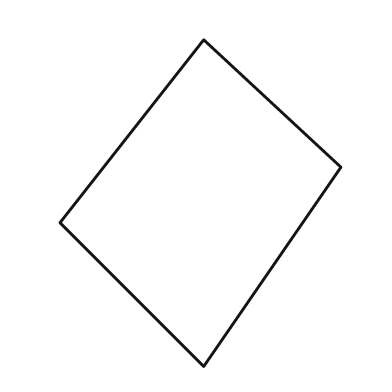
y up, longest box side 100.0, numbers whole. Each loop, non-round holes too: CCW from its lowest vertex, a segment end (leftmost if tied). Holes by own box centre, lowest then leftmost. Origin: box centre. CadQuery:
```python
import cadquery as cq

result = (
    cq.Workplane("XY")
    .moveTo(1.0, -50.0)
    .lineTo(43.0, 11.0)
    .lineTo(1.0, 50.0)
    .lineTo(-43.0, -6.0)
    .close()
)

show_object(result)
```